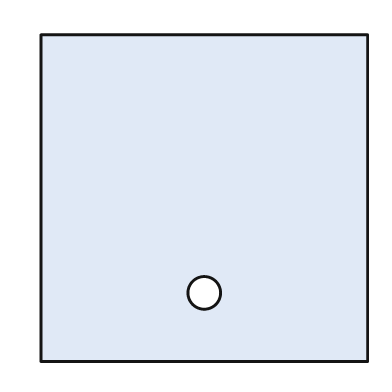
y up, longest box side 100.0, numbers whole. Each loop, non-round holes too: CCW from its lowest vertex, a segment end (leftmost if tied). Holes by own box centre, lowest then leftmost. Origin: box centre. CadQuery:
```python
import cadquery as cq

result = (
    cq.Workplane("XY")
    .moveTo(-50.0, -50.0)
    .lineTo(50.0, -50.0)
    .lineTo(50.0, 50.0)
    .lineTo(-50.0, 50.0)
    .close()
    .moveTo(0.0, -29.0)
    .circle(5.0)
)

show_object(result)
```